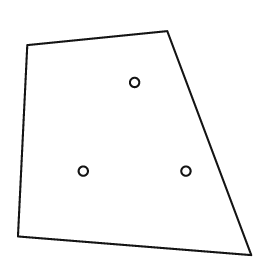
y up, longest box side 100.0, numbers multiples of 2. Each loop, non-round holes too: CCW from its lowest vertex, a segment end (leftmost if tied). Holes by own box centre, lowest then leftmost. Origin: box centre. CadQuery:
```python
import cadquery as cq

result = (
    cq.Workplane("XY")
    .moveTo(50.0, -48.0)
    .lineTo(14.0, 48.0)
    .lineTo(-46.0, 42.0)
    .lineTo(-50.0, -40.0)
    .close()
    .moveTo(-22.0, -12.0)
    .circle(2.0)
    .moveTo(22.0, -12.0)
    .circle(2.0)
    .moveTo(0.0, 26.0)
    .circle(2.0)
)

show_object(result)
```